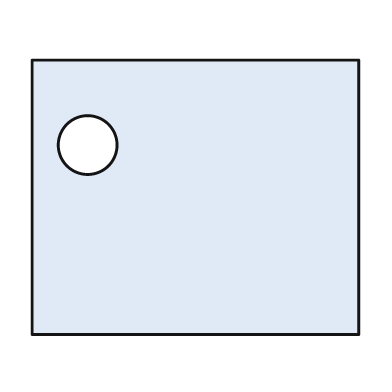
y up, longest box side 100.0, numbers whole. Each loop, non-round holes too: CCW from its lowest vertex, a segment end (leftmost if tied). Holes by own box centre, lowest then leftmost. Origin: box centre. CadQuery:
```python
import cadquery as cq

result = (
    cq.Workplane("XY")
    .moveTo(-50.0, -42.0)
    .lineTo(50.0, -42.0)
    .lineTo(50.0, 42.0)
    .lineTo(-50.0, 42.0)
    .close()
    .moveTo(-33.0, 16.0)
    .circle(9.0)
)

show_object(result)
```